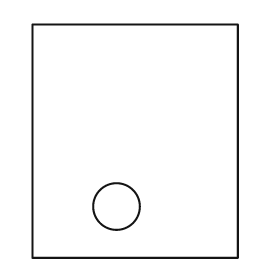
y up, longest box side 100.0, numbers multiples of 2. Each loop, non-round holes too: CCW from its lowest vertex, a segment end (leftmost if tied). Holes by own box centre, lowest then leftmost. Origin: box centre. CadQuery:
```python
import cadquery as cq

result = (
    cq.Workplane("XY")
    .moveTo(-44.0, -50.0)
    .lineTo(44.0, -50.0)
    .lineTo(44.0, 50.0)
    .lineTo(-44.0, 50.0)
    .close()
    .moveTo(-8.0, -28.0)
    .circle(10.0)
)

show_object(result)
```